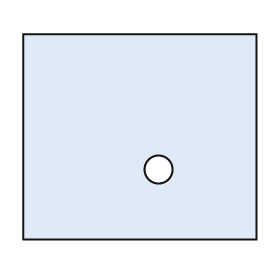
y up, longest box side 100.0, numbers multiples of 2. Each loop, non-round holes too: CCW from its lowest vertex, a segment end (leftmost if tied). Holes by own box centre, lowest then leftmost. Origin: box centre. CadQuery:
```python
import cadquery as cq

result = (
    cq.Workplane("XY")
    .moveTo(-50.0, -44.0)
    .lineTo(50.0, -44.0)
    .lineTo(50.0, 44.0)
    .lineTo(-50.0, 44.0)
    .close()
    .moveTo(8.0, -14.0)
    .circle(6.0)
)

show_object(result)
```